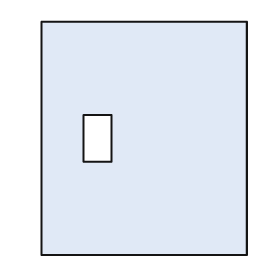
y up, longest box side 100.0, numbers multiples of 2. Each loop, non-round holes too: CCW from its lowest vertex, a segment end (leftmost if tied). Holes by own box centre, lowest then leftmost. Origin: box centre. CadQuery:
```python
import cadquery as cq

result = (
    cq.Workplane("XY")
    .moveTo(-44.0, -50.0)
    .lineTo(44.0, -50.0)
    .lineTo(44.0, 50.0)
    .lineTo(-44.0, 50.0)
    .close()
    .moveTo(-26.0, -10.0)
    .lineTo(-14.0, -10.0)
    .lineTo(-14.0, 10.0)
    .lineTo(-26.0, 10.0)
    .close()
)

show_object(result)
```